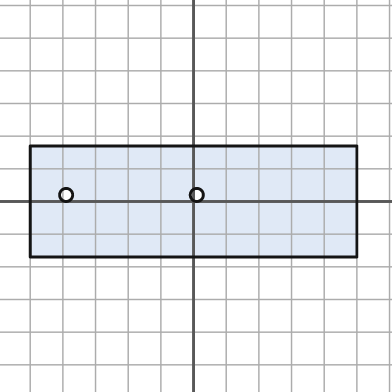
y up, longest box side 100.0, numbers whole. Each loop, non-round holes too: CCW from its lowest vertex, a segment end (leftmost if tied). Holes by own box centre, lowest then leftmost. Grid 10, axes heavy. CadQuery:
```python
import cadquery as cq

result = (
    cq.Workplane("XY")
    .moveTo(-50.0, -17.0)
    .lineTo(50.0, -17.0)
    .lineTo(50.0, 17.0)
    .lineTo(-50.0, 17.0)
    .close()
    .moveTo(-39.0, 2.0)
    .circle(2.0)
    .moveTo(1.0, 2.0)
    .circle(2.0)
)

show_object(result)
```